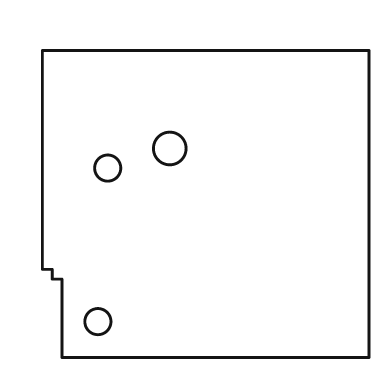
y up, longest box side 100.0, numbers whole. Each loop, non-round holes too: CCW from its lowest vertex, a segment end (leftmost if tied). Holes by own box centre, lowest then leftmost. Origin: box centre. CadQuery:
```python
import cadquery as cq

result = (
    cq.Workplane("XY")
    .moveTo(-44.0, -47.0)
    .lineTo(50.0, -47.0)
    .lineTo(50.0, 47.0)
    .lineTo(-50.0, 47.0)
    .lineTo(-50.0, -20.0)
    .lineTo(-47.0, -20.0)
    .lineTo(-47.0, -23.0)
    .lineTo(-44.0, -23.0)
    .close()
    .moveTo(-33.0, -36.0)
    .circle(4.0)
    .moveTo(-30.0, 11.0)
    .circle(4.0)
    .moveTo(-11.0, 17.0)
    .circle(5.0)
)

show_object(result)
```